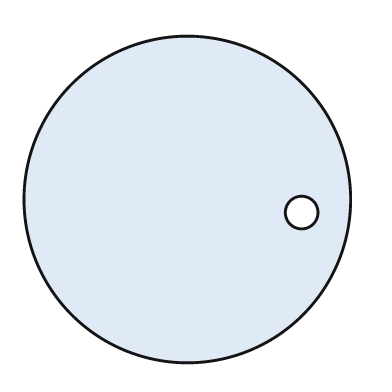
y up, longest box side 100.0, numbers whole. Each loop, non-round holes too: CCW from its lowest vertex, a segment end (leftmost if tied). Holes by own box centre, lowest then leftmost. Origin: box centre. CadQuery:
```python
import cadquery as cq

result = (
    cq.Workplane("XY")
    .moveTo(0.0, 0.0)
    .circle(50.0)
    .moveTo(35.0, -4.0)
    .circle(5.0)
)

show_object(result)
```